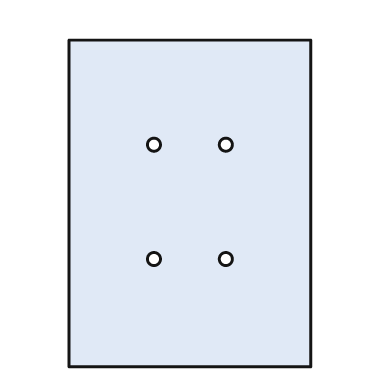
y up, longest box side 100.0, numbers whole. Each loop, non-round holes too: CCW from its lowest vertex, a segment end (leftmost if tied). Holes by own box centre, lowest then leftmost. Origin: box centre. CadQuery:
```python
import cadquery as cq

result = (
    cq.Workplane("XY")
    .moveTo(-37.0, -50.0)
    .lineTo(37.0, -50.0)
    .lineTo(37.0, 50.0)
    .lineTo(-37.0, 50.0)
    .close()
    .moveTo(-11.0, -17.0)
    .circle(2.0)
    .moveTo(11.0, -17.0)
    .circle(2.0)
    .moveTo(-11.0, 18.0)
    .circle(2.0)
    .moveTo(11.0, 18.0)
    .circle(2.0)
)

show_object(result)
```